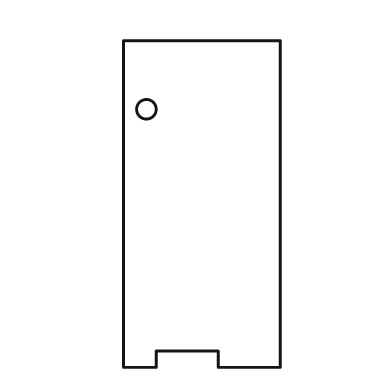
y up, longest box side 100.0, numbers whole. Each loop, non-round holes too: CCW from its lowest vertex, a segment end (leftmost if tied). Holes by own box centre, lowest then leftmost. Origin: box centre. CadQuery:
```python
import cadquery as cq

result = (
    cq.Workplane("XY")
    .moveTo(-24.0, -50.0)
    .lineTo(-14.0, -50.0)
    .lineTo(-14.0, -45.0)
    .lineTo(5.0, -45.0)
    .lineTo(5.0, -50.0)
    .lineTo(24.0, -50.0)
    .lineTo(24.0, 50.0)
    .lineTo(-24.0, 50.0)
    .close()
    .moveTo(-17.0, 29.0)
    .circle(3.0)
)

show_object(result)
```